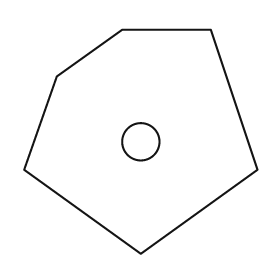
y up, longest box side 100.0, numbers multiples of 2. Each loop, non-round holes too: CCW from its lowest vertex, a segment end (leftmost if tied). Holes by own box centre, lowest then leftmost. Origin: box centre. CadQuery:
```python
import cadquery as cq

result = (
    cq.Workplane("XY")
    .moveTo(0.0, -48.0)
    .lineTo(50.0, -12.0)
    .lineTo(30.0, 48.0)
    .lineTo(-8.0, 48.0)
    .lineTo(-36.0, 28.0)
    .lineTo(-50.0, -12.0)
    .close()
    .moveTo(0.0, 0.0)
    .circle(8.0)
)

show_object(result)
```